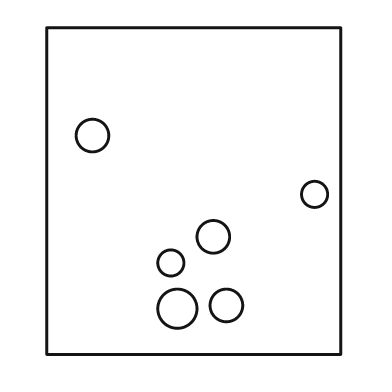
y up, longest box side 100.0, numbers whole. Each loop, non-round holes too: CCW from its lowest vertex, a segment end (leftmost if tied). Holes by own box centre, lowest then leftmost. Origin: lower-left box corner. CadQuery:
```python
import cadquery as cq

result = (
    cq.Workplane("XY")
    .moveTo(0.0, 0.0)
    .lineTo(90.0, 0.0)
    .lineTo(90.0, 100.0)
    .lineTo(0.0, 100.0)
    .close()
    .moveTo(40.0, 14.0)
    .circle(6.0)
    .moveTo(55.0, 15.0)
    .circle(5.0)
    .moveTo(38.0, 28.0)
    .circle(4.0)
    .moveTo(51.0, 36.0)
    .circle(5.0)
    .moveTo(82.0, 49.0)
    .circle(4.0)
    .moveTo(14.0, 67.0)
    .circle(5.0)
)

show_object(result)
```